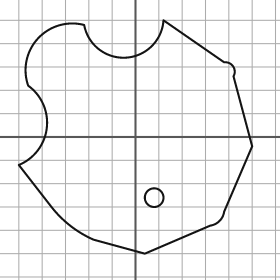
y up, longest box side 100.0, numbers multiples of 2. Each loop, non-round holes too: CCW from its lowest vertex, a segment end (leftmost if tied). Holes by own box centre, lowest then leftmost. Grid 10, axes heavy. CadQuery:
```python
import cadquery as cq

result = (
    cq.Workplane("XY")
    .moveTo(4.0, -50.0)
    .lineTo(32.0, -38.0)
    .threePointArc((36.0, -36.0), (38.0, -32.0))
    .lineTo(50.0, -4.0)
    .lineTo(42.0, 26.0)
    .threePointArc((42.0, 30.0), (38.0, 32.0))
    .lineTo(12.0, 50.0)
    .threePointArc((-4.0, 34.0), (-22.0, 48.0))
    .threePointArc((-42.0, 42.0), (-46.0, 22.0))
    .threePointArc((-38.0, 4.0), (-50.0, -12.0))
    .lineTo(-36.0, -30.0)
    .threePointArc((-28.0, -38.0), (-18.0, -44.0))
    .close()
    .moveTo(8.0, -26.0)
    .circle(4.0)
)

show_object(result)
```